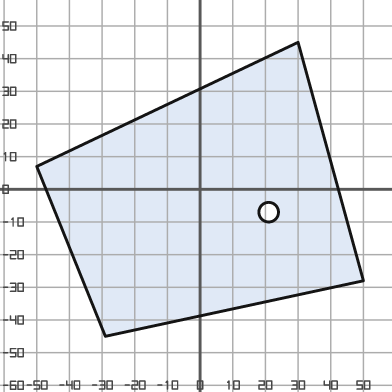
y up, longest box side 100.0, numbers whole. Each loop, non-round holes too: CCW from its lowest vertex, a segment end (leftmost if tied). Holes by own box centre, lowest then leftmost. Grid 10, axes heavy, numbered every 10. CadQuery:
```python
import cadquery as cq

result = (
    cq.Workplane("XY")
    .moveTo(-29.0, -45.0)
    .lineTo(50.0, -28.0)
    .lineTo(30.0, 45.0)
    .lineTo(-50.0, 7.0)
    .close()
    .moveTo(21.0, -7.0)
    .circle(3.0)
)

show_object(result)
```